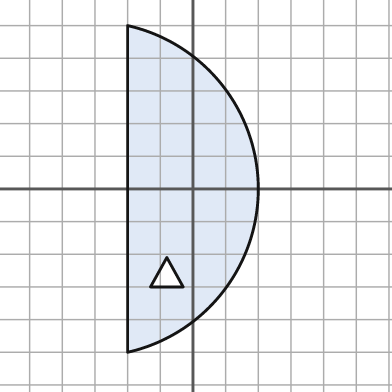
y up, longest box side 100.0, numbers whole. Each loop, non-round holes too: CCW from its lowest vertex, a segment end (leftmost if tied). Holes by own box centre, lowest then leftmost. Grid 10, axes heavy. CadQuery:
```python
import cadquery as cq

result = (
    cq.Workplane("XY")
    .moveTo(-20.0, -50.0)
    .threePointArc((20.0, 0.0), (-20.0, 50.0))
    .close()
    .moveTo(-13.0, -30.0)
    .lineTo(-3.0, -30.0)
    .lineTo(-8.0, -21.0)
    .close()
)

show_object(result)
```